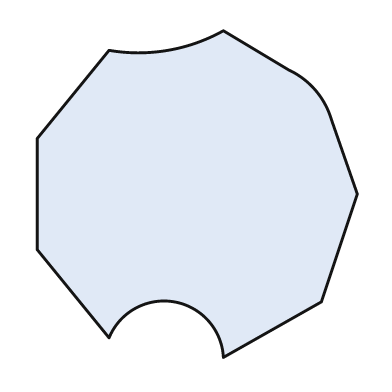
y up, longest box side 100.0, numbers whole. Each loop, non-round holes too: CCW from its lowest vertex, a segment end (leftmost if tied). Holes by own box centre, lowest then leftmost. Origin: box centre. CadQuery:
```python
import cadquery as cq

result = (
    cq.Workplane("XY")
    .moveTo(8.0, -50.0)
    .lineTo(38.0, -33.0)
    .lineTo(49.0, 0.0)
    .lineTo(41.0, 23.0)
    .threePointArc((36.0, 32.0), (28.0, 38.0))
    .lineTo(8.0, 50.0)
    .threePointArc((-9.0, 44.0), (-27.0, 44.0))
    .lineTo(-49.0, 17.0)
    .lineTo(-49.0, -17.0)
    .lineTo(-27.0, -44.0)
    .threePointArc((-7.0, -33.0), (8.0, -50.0))
    .close()
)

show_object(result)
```